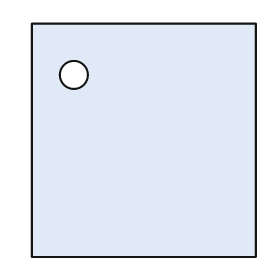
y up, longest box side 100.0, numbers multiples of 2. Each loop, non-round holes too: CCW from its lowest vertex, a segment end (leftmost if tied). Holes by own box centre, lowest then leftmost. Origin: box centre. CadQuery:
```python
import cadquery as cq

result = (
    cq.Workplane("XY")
    .moveTo(-48.0, -50.0)
    .lineTo(48.0, -50.0)
    .lineTo(48.0, 50.0)
    .lineTo(-48.0, 50.0)
    .close()
    .moveTo(-30.0, 28.0)
    .circle(6.0)
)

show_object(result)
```